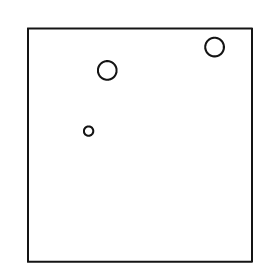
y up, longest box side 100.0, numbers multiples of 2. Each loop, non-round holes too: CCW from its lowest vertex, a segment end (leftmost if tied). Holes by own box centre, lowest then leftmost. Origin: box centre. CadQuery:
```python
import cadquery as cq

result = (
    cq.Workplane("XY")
    .moveTo(-48.0, -50.0)
    .lineTo(48.0, -50.0)
    .lineTo(48.0, 50.0)
    .lineTo(-48.0, 50.0)
    .close()
    .moveTo(-22.0, 6.0)
    .circle(2.0)
    .moveTo(-14.0, 32.0)
    .circle(4.0)
    .moveTo(32.0, 42.0)
    .circle(4.0)
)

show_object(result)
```